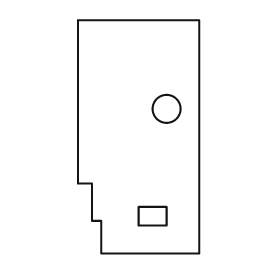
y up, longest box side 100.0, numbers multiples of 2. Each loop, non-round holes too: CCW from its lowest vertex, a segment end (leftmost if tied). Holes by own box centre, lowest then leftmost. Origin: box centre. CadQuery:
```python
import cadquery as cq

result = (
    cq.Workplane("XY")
    .moveTo(-16.0, -50.0)
    .lineTo(26.0, -50.0)
    .lineTo(26.0, 50.0)
    .lineTo(-26.0, 50.0)
    .lineTo(-26.0, -20.0)
    .lineTo(-20.0, -20.0)
    .lineTo(-20.0, -36.0)
    .lineTo(-16.0, -36.0)
    .close()
    .moveTo(0.0, -38.0)
    .lineTo(12.0, -38.0)
    .lineTo(12.0, -30.0)
    .lineTo(0.0, -30.0)
    .close()
    .moveTo(12.0, 12.0)
    .circle(6.0)
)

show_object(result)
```